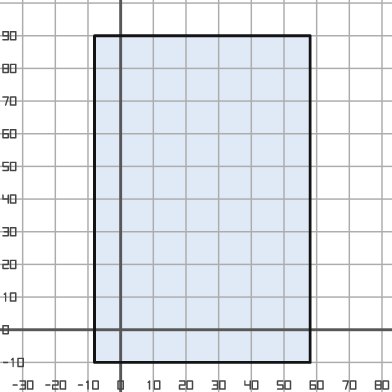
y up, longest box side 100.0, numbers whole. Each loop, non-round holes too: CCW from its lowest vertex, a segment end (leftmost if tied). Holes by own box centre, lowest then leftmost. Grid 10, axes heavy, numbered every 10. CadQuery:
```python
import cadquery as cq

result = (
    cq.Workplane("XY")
    .moveTo(-8.0, -10.0)
    .lineTo(58.0, -10.0)
    .lineTo(58.0, 90.0)
    .lineTo(-8.0, 90.0)
    .close()
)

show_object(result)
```